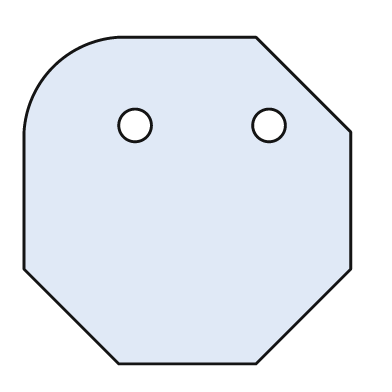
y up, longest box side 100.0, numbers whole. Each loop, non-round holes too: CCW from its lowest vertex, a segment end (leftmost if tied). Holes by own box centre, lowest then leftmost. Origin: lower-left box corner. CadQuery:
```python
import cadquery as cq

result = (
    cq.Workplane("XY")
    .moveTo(29.0, 0.0)
    .lineTo(71.0, 0.0)
    .lineTo(100.0, 29.0)
    .lineTo(100.0, 71.0)
    .lineTo(71.0, 100.0)
    .lineTo(29.0, 100.0)
    .threePointArc((9.0, 91.0), (0.0, 71.0))
    .lineTo(0.0, 29.0)
    .close()
    .moveTo(34.0, 73.0)
    .circle(5.0)
    .moveTo(75.0, 73.0)
    .circle(5.0)
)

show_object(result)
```